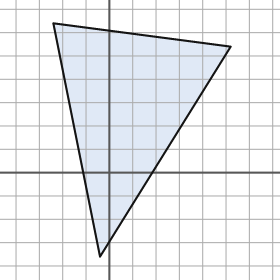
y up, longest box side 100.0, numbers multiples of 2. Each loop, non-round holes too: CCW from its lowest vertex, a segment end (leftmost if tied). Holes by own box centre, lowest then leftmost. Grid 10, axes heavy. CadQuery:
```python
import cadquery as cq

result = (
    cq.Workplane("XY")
    .moveTo(-4.0, -36.0)
    .lineTo(52.0, 54.0)
    .lineTo(-24.0, 64.0)
    .close()
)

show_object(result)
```